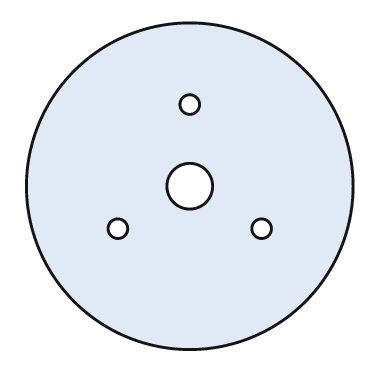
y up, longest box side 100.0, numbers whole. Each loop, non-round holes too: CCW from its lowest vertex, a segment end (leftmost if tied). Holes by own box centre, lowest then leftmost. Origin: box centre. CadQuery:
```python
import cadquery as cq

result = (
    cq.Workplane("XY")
    .moveTo(0.0, 0.0)
    .circle(50.0)
    .moveTo(-22.0, -13.0)
    .circle(3.0)
    .moveTo(22.0, -13.0)
    .circle(3.0)
    .moveTo(0.0, 0.0)
    .circle(7.0)
    .moveTo(0.0, 25.0)
    .circle(3.0)
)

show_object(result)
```